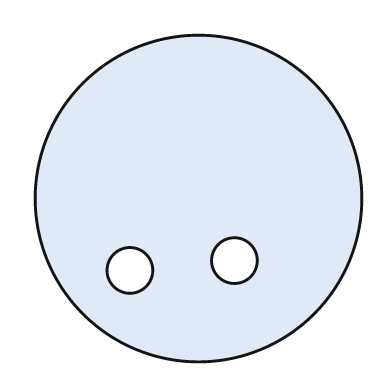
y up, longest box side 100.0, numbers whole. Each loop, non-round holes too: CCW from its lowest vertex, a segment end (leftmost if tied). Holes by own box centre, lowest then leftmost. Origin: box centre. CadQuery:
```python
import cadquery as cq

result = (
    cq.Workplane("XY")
    .moveTo(0.0, 0.0)
    .circle(50.0)
    .moveTo(-21.0, -22.0)
    .circle(7.0)
    .moveTo(11.0, -19.0)
    .circle(7.0)
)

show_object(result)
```